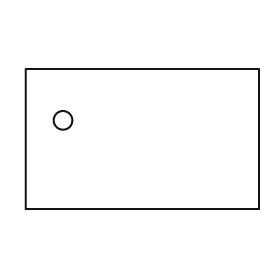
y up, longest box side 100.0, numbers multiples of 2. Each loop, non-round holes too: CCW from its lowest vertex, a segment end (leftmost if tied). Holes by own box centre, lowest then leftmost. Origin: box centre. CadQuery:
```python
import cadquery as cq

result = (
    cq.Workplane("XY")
    .moveTo(-50.0, -30.0)
    .lineTo(50.0, -30.0)
    .lineTo(50.0, 30.0)
    .lineTo(-50.0, 30.0)
    .close()
    .moveTo(-34.0, 8.0)
    .circle(4.0)
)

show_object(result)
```